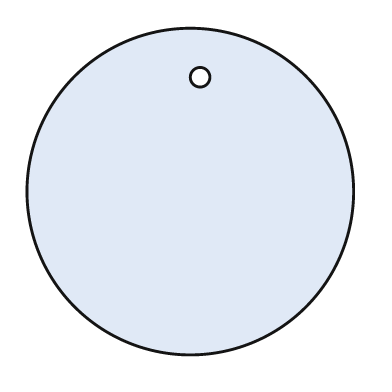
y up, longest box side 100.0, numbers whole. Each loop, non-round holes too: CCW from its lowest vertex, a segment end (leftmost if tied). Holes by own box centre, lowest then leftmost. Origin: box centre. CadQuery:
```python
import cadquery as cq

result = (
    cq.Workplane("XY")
    .moveTo(0.0, 0.0)
    .circle(50.0)
    .moveTo(3.0, 35.0)
    .circle(3.0)
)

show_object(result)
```